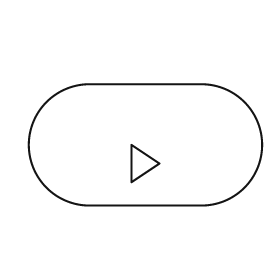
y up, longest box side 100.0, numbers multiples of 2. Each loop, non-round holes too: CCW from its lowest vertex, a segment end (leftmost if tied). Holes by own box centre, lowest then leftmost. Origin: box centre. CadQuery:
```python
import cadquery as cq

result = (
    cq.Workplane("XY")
    .moveTo(-24.0, -26.0)
    .lineTo(24.0, -26.0)
    .threePointArc((50.0, 0.0), (24.0, 26.0))
    .lineTo(-24.0, 26.0)
    .threePointArc((-50.0, 0.0), (-24.0, -26.0))
    .close()
    .moveTo(-6.0, -16.0)
    .lineTo(6.0, -8.0)
    .lineTo(-6.0, 0.0)
    .close()
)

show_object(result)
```